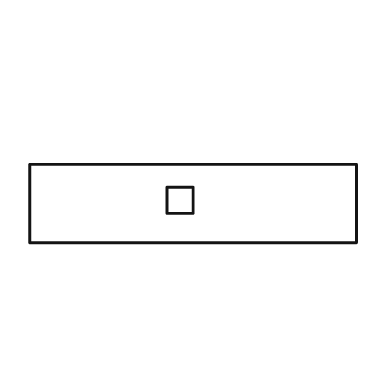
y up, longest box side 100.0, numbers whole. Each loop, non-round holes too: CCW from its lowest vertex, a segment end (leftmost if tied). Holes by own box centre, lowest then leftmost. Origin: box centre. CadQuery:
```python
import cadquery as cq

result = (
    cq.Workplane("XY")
    .moveTo(-50.0, -12.0)
    .lineTo(50.0, -12.0)
    .lineTo(50.0, 12.0)
    .lineTo(-50.0, 12.0)
    .close()
    .moveTo(-8.0, -3.0)
    .lineTo(0.0, -3.0)
    .lineTo(0.0, 5.0)
    .lineTo(-8.0, 5.0)
    .close()
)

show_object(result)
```